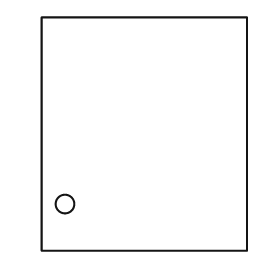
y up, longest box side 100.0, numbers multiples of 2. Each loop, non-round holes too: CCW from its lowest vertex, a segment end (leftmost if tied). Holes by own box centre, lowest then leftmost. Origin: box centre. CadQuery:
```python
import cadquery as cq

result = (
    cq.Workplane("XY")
    .moveTo(-44.0, -50.0)
    .lineTo(44.0, -50.0)
    .lineTo(44.0, 50.0)
    .lineTo(-44.0, 50.0)
    .close()
    .moveTo(-34.0, -30.0)
    .circle(4.0)
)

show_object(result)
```